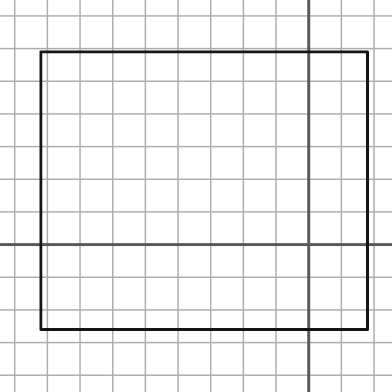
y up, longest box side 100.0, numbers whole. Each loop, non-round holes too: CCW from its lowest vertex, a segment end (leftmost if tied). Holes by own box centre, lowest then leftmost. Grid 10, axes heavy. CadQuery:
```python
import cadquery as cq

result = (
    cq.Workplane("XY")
    .moveTo(-82.0, -26.0)
    .lineTo(18.0, -26.0)
    .lineTo(18.0, 59.0)
    .lineTo(-82.0, 59.0)
    .close()
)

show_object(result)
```